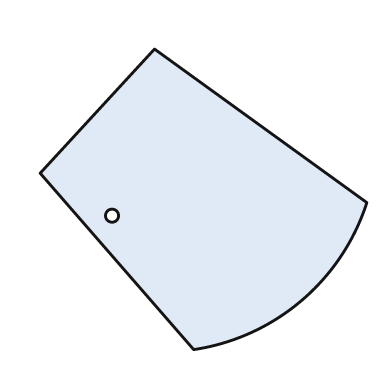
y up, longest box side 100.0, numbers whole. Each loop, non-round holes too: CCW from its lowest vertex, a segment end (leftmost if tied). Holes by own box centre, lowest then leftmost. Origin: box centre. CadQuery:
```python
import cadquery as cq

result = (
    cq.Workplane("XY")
    .moveTo(-3.0, -46.0)
    .threePointArc((30.0, -31.0), (50.0, -1.0))
    .lineTo(-15.0, 46.0)
    .lineTo(-50.0, 8.0)
    .close()
    .moveTo(-28.0, -5.0)
    .circle(2.0)
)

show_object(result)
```